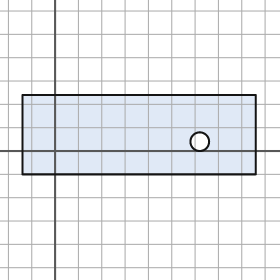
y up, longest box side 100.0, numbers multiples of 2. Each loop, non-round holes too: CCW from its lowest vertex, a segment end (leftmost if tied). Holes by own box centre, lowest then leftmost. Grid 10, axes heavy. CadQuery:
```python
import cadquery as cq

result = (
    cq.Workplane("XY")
    .moveTo(-14.0, -10.0)
    .lineTo(86.0, -10.0)
    .lineTo(86.0, 24.0)
    .lineTo(-14.0, 24.0)
    .close()
    .moveTo(62.0, 4.0)
    .circle(4.0)
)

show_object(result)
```